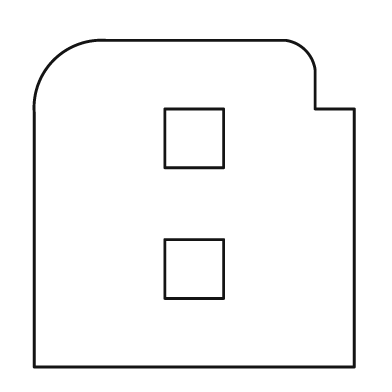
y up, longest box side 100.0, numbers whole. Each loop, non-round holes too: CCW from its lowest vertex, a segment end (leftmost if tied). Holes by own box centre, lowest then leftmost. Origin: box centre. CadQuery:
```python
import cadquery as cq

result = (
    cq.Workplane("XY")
    .moveTo(-49.0, -50.0)
    .lineTo(49.0, -50.0)
    .lineTo(49.0, 29.0)
    .lineTo(37.0, 29.0)
    .lineTo(37.0, 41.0)
    .threePointArc((34.0, 47.0), (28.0, 50.0))
    .lineTo(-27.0, 50.0)
    .threePointArc((-43.0, 44.0), (-49.0, 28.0))
    .close()
    .moveTo(-9.0, -29.0)
    .lineTo(9.0, -29.0)
    .lineTo(9.0, -11.0)
    .lineTo(-9.0, -11.0)
    .close()
    .moveTo(-9.0, 11.0)
    .lineTo(9.0, 11.0)
    .lineTo(9.0, 29.0)
    .lineTo(-9.0, 29.0)
    .close()
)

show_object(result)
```